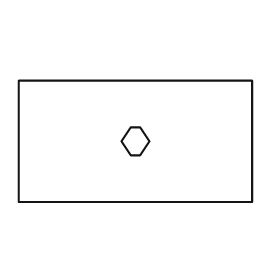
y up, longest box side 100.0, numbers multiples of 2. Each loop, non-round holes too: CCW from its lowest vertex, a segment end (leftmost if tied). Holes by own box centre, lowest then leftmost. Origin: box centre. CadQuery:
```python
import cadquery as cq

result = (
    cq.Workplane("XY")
    .moveTo(-50.0, -26.0)
    .lineTo(50.0, -26.0)
    .lineTo(50.0, 26.0)
    .lineTo(-50.0, 26.0)
    .close()
    .moveTo(-2.0, -6.0)
    .lineTo(2.0, -6.0)
    .lineTo(6.0, 0.0)
    .lineTo(2.0, 6.0)
    .lineTo(-2.0, 6.0)
    .lineTo(-6.0, 0.0)
    .close()
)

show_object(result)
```